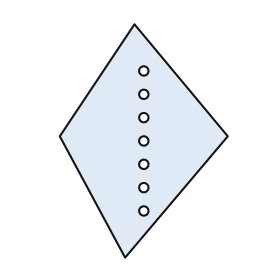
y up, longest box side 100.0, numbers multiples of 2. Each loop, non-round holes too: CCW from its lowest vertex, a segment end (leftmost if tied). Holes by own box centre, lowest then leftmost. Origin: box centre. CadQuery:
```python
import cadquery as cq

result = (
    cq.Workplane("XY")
    .moveTo(-8.0, -50.0)
    .lineTo(36.0, 2.0)
    .lineTo(-4.0, 50.0)
    .lineTo(-36.0, 2.0)
    .close()
    .moveTo(0.0, -30.0)
    .circle(2.0)
    .moveTo(0.0, -20.0)
    .circle(2.0)
    .moveTo(0.0, -10.0)
    .circle(2.0)
    .moveTo(0.0, 0.0)
    .circle(2.0)
    .moveTo(0.0, 10.0)
    .circle(2.0)
    .moveTo(0.0, 20.0)
    .circle(2.0)
    .moveTo(0.0, 30.0)
    .circle(2.0)
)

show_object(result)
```